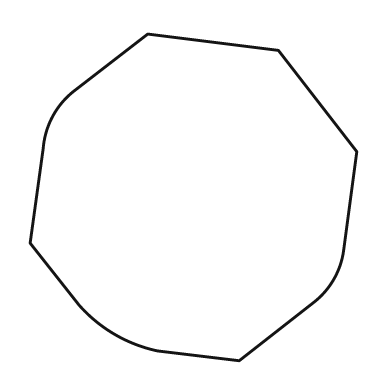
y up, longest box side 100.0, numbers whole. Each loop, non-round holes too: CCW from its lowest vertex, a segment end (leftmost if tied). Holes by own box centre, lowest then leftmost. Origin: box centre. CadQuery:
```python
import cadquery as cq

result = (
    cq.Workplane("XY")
    .moveTo(14.0, -50.0)
    .lineTo(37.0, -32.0)
    .threePointArc((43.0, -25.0), (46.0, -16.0))
    .lineTo(50.0, 14.0)
    .lineTo(26.0, 45.0)
    .lineTo(-14.0, 50.0)
    .lineTo(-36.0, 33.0)
    .threePointArc((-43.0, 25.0), (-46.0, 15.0))
    .lineTo(-50.0, -14.0)
    .lineTo(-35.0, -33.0)
    .threePointArc((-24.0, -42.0), (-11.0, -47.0))
    .close()
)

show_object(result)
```